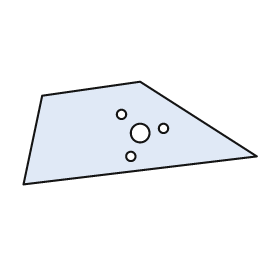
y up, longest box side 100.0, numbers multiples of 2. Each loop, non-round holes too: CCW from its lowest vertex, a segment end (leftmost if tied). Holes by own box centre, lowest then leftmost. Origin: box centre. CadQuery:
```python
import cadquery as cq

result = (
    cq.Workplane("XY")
    .moveTo(-50.0, -22.0)
    .lineTo(50.0, -10.0)
    .lineTo(0.0, 22.0)
    .lineTo(-42.0, 16.0)
    .close()
    .moveTo(-4.0, -10.0)
    .circle(2.0)
    .moveTo(0.0, 0.0)
    .circle(4.0)
    .moveTo(10.0, 2.0)
    .circle(2.0)
    .moveTo(-8.0, 8.0)
    .circle(2.0)
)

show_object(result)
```